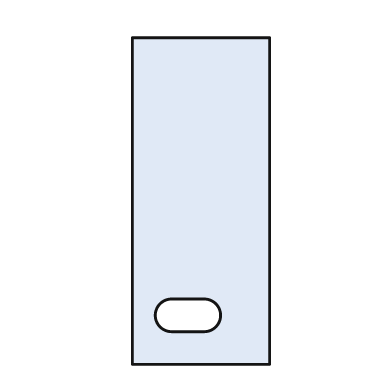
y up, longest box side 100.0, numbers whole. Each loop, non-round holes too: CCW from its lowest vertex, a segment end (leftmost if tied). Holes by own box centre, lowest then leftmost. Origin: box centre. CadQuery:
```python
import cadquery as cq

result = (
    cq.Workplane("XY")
    .moveTo(-21.0, -50.0)
    .lineTo(21.0, -50.0)
    .lineTo(21.0, 50.0)
    .lineTo(-21.0, 50.0)
    .close()
    .moveTo(-9.0, -40.0)
    .lineTo(1.0, -40.0)
    .threePointArc((6.0, -35.0), (1.0, -30.0))
    .lineTo(-9.0, -30.0)
    .threePointArc((-14.0, -35.0), (-9.0, -40.0))
    .close()
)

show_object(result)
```